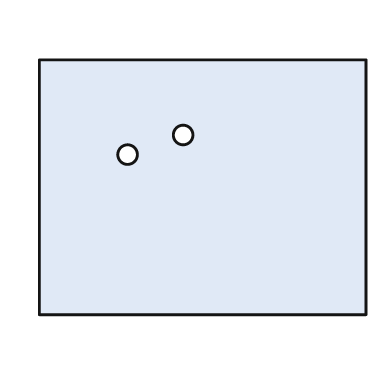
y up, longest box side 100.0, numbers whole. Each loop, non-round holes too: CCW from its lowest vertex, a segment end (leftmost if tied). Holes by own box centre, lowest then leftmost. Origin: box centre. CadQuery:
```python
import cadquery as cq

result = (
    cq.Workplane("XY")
    .moveTo(-50.0, -39.0)
    .lineTo(50.0, -39.0)
    .lineTo(50.0, 39.0)
    .lineTo(-50.0, 39.0)
    .close()
    .moveTo(-23.0, 10.0)
    .circle(3.0)
    .moveTo(-6.0, 16.0)
    .circle(3.0)
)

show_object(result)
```